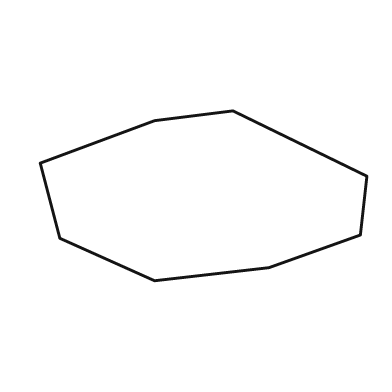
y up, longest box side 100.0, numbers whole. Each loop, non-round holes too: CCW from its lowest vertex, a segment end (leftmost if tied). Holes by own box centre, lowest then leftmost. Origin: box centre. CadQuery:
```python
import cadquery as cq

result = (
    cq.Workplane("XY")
    .moveTo(-15.0, -26.0)
    .lineTo(20.0, -22.0)
    .lineTo(48.0, -12.0)
    .lineTo(50.0, 6.0)
    .lineTo(9.0, 26.0)
    .lineTo(-15.0, 23.0)
    .lineTo(-50.0, 10.0)
    .lineTo(-44.0, -13.0)
    .close()
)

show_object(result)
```